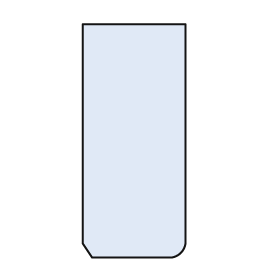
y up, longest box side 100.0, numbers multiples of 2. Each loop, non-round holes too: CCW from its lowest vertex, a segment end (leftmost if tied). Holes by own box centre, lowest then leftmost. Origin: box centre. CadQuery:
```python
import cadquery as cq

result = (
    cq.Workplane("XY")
    .moveTo(-18.0, -50.0)
    .lineTo(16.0, -50.0)
    .threePointArc((20.0, -48.0), (22.0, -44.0))
    .lineTo(22.0, 50.0)
    .lineTo(-22.0, 50.0)
    .lineTo(-22.0, -44.0)
    .close()
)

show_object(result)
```